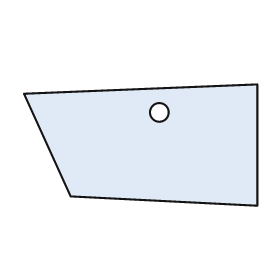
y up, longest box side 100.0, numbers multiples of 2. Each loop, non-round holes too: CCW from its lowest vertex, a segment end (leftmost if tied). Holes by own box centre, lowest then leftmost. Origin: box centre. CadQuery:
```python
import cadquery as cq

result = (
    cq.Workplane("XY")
    .moveTo(50.0, -26.0)
    .lineTo(50.0, 26.0)
    .lineTo(-50.0, 22.0)
    .lineTo(-30.0, -22.0)
    .close()
    .moveTo(8.0, 14.0)
    .circle(4.0)
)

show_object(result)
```